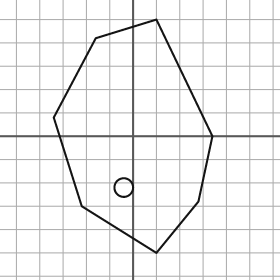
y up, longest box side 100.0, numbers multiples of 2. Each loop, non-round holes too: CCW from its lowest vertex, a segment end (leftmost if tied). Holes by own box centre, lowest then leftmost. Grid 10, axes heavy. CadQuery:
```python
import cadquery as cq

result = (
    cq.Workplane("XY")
    .moveTo(10.0, -50.0)
    .lineTo(28.0, -28.0)
    .lineTo(34.0, 0.0)
    .lineTo(10.0, 50.0)
    .lineTo(-16.0, 42.0)
    .lineTo(-34.0, 8.0)
    .lineTo(-22.0, -30.0)
    .close()
    .moveTo(-4.0, -22.0)
    .circle(4.0)
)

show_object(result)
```